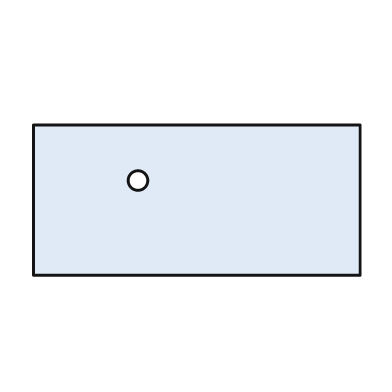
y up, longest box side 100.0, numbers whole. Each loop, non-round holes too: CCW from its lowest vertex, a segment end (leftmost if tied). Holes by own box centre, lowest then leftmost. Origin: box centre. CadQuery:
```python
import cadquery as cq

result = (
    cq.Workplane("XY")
    .moveTo(-50.0, -23.0)
    .lineTo(50.0, -23.0)
    .lineTo(50.0, 23.0)
    .lineTo(-50.0, 23.0)
    .close()
    .moveTo(-18.0, 6.0)
    .circle(3.0)
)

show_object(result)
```